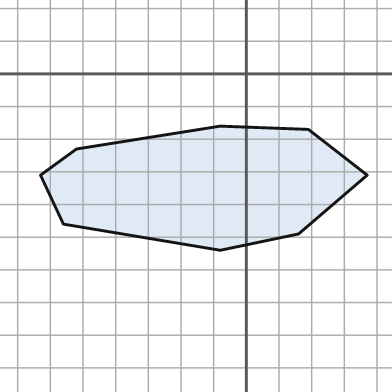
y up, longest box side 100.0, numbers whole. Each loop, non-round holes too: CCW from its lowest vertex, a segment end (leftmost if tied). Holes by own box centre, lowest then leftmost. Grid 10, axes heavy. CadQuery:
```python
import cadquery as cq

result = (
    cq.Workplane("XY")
    .moveTo(-8.0, -54.0)
    .lineTo(16.0, -49.0)
    .lineTo(37.0, -31.0)
    .lineTo(19.0, -17.0)
    .lineTo(-8.0, -16.0)
    .lineTo(-52.0, -23.0)
    .lineTo(-63.0, -31.0)
    .lineTo(-56.0, -46.0)
    .close()
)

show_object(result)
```